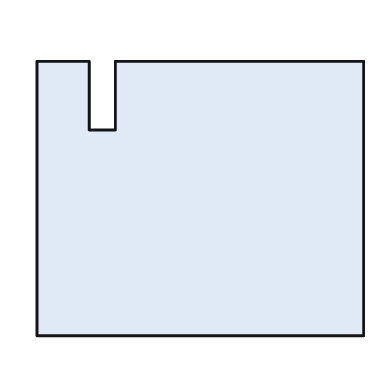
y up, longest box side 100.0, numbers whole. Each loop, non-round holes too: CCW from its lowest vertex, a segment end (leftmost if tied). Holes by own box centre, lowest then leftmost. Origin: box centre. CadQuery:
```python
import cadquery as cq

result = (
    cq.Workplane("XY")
    .moveTo(-50.0, -42.0)
    .lineTo(50.0, -42.0)
    .lineTo(50.0, 42.0)
    .lineTo(-26.0, 42.0)
    .lineTo(-26.0, 21.0)
    .lineTo(-34.0, 21.0)
    .lineTo(-34.0, 42.0)
    .lineTo(-50.0, 42.0)
    .close()
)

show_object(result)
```